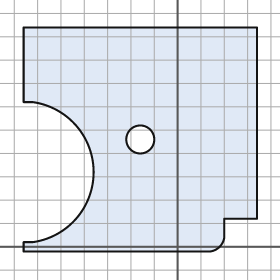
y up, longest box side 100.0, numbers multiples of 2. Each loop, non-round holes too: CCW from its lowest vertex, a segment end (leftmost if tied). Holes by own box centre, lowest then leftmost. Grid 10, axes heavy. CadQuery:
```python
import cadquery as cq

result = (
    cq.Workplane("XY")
    .moveTo(-66.0, -2.0)
    .lineTo(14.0, -2.0)
    .threePointArc((18.0, 0.0), (20.0, 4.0))
    .lineTo(20.0, 12.0)
    .lineTo(34.0, 12.0)
    .lineTo(34.0, 94.0)
    .lineTo(-66.0, 94.0)
    .lineTo(-66.0, 62.0)
    .lineTo(-62.0, 62.0)
    .threePointArc((-36.0, 32.0), (-62.0, 2.0))
    .lineTo(-66.0, 2.0)
    .close()
    .moveTo(-16.0, 46.0)
    .circle(6.0)
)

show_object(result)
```